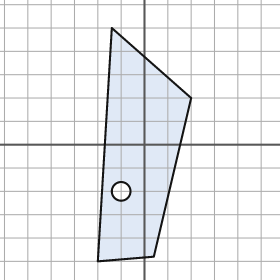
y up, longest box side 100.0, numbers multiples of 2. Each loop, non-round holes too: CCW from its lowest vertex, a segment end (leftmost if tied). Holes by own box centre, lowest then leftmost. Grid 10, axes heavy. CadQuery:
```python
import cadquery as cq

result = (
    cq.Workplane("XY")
    .moveTo(-20.0, -50.0)
    .lineTo(4.0, -48.0)
    .lineTo(20.0, 20.0)
    .lineTo(-14.0, 50.0)
    .close()
    .moveTo(-10.0, -20.0)
    .circle(4.0)
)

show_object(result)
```